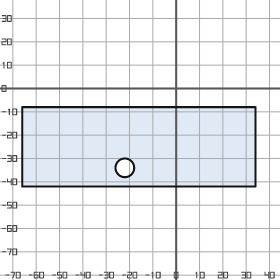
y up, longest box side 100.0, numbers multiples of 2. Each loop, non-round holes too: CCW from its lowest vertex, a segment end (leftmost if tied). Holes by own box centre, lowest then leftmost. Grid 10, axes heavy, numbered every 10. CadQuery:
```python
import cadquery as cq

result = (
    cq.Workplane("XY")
    .moveTo(-66.0, -42.0)
    .lineTo(34.0, -42.0)
    .lineTo(34.0, -8.0)
    .lineTo(-66.0, -8.0)
    .close()
    .moveTo(-22.0, -34.0)
    .circle(4.0)
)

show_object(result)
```